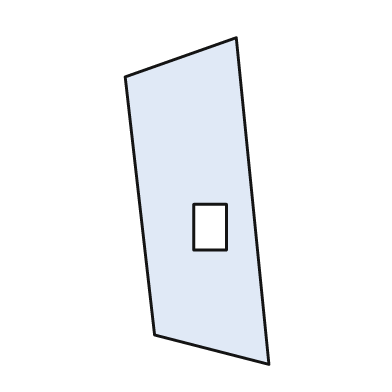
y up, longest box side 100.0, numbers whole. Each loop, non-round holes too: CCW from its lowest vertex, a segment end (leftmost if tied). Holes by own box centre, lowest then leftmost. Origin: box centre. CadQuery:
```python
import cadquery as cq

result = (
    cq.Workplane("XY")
    .moveTo(22.0, -50.0)
    .lineTo(12.0, 50.0)
    .lineTo(-22.0, 38.0)
    .lineTo(-13.0, -41.0)
    .close()
    .moveTo(-1.0, -15.0)
    .lineTo(9.0, -15.0)
    .lineTo(9.0, -1.0)
    .lineTo(-1.0, -1.0)
    .close()
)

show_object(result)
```